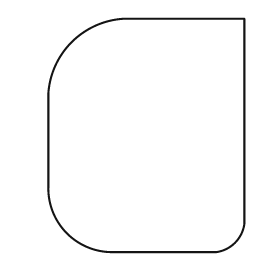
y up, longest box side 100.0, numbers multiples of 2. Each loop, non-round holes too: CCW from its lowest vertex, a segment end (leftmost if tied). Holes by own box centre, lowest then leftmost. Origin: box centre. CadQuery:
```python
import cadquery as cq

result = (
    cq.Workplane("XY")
    .moveTo(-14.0, -50.0)
    .lineTo(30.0, -50.0)
    .threePointArc((38.0, -46.0), (42.0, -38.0))
    .lineTo(42.0, 50.0)
    .lineTo(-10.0, 50.0)
    .threePointArc((-32.0, 40.0), (-42.0, 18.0))
    .lineTo(-42.0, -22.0)
    .threePointArc((-34.0, -42.0), (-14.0, -50.0))
    .close()
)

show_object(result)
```